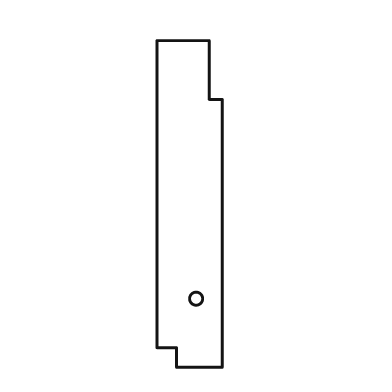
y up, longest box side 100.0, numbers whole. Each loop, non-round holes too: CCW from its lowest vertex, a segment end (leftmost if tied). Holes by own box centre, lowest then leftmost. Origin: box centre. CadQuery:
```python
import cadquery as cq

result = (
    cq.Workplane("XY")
    .moveTo(-4.0, -50.0)
    .lineTo(10.0, -50.0)
    .lineTo(10.0, 32.0)
    .lineTo(6.0, 32.0)
    .lineTo(6.0, 50.0)
    .lineTo(-10.0, 50.0)
    .lineTo(-10.0, -44.0)
    .lineTo(-4.0, -44.0)
    .close()
    .moveTo(2.0, -29.0)
    .circle(2.0)
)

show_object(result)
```